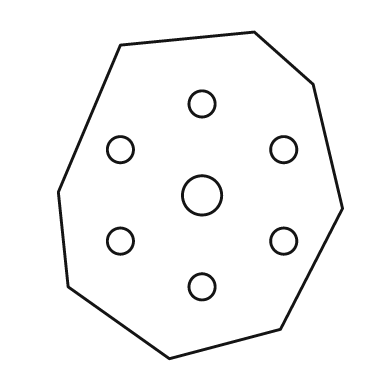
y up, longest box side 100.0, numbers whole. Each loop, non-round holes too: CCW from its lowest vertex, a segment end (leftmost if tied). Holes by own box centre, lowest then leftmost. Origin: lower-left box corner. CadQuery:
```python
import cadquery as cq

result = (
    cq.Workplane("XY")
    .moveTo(34.0, 0.0)
    .lineTo(68.0, 9.0)
    .lineTo(87.0, 46.0)
    .lineTo(78.0, 84.0)
    .lineTo(60.0, 100.0)
    .lineTo(19.0, 96.0)
    .lineTo(0.0, 51.0)
    .lineTo(3.0, 22.0)
    .close()
    .moveTo(44.0, 22.0)
    .circle(4.0)
    .moveTo(19.0, 36.0)
    .circle(4.0)
    .moveTo(69.0, 36.0)
    .circle(4.0)
    .moveTo(44.0, 50.0)
    .circle(6.0)
    .moveTo(19.0, 64.0)
    .circle(4.0)
    .moveTo(69.0, 64.0)
    .circle(4.0)
    .moveTo(44.0, 78.0)
    .circle(4.0)
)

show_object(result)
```